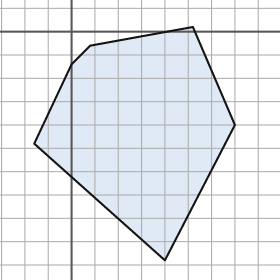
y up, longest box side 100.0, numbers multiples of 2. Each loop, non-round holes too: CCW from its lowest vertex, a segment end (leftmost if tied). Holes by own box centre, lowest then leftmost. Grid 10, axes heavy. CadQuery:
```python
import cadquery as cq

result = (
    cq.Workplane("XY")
    .moveTo(40.0, -98.0)
    .lineTo(70.0, -40.0)
    .lineTo(52.0, 2.0)
    .lineTo(8.0, -6.0)
    .lineTo(0.0, -14.0)
    .lineTo(-16.0, -48.0)
    .close()
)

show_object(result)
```